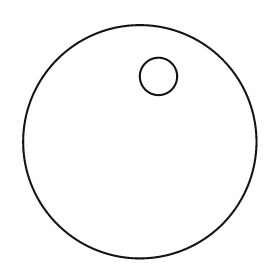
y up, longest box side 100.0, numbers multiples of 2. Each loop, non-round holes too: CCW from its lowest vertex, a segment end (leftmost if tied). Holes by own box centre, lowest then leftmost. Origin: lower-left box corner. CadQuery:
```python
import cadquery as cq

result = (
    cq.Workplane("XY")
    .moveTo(50.0, 50.0)
    .circle(50.0)
    .moveTo(58.0, 78.0)
    .circle(8.0)
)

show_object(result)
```